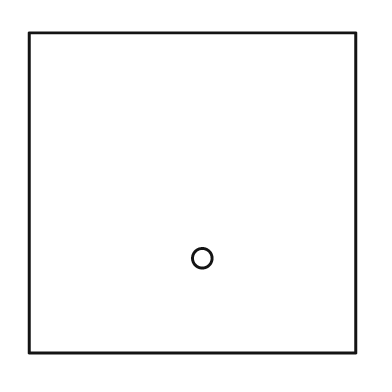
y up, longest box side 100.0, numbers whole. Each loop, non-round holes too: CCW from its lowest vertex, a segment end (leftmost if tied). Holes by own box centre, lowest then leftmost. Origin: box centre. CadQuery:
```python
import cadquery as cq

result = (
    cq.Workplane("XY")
    .moveTo(-50.0, -49.0)
    .lineTo(50.0, -49.0)
    .lineTo(50.0, 49.0)
    .lineTo(-50.0, 49.0)
    .close()
    .moveTo(3.0, -20.0)
    .circle(3.0)
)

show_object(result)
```